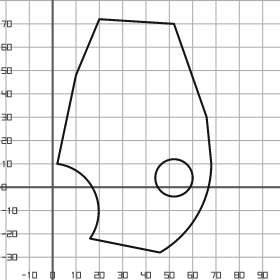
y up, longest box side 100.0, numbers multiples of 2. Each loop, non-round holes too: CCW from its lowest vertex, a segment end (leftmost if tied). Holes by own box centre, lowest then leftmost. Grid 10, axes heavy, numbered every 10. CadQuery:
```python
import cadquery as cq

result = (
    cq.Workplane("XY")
    .moveTo(46.0, -28.0)
    .threePointArc((62.0, -12.0), (68.0, 10.0))
    .lineTo(66.0, 30.0)
    .lineTo(52.0, 70.0)
    .lineTo(20.0, 72.0)
    .lineTo(10.0, 48.0)
    .lineTo(2.0, 10.0)
    .threePointArc((18.0, -2.0), (16.0, -22.0))
    .close()
    .moveTo(52.0, 4.0)
    .circle(8.0)
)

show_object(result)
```